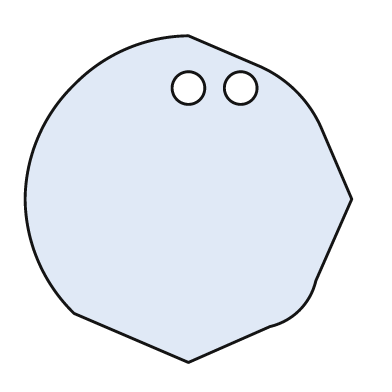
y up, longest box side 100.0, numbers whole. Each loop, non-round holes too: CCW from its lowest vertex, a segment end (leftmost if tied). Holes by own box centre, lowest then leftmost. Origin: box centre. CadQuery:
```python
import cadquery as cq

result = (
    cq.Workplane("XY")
    .moveTo(0.0, -50.0)
    .lineTo(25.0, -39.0)
    .threePointArc((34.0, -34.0), (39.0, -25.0))
    .lineTo(50.0, 0.0)
    .lineTo(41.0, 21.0)
    .threePointArc((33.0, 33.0), (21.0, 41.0))
    .lineTo(0.0, 50.0)
    .threePointArc((-19.0, 46.0), (-35.0, 35.0))
    .threePointArc((-46.0, 19.0), (-50.0, 0.0))
    .threePointArc((-46.0, -19.0), (-35.0, -35.0))
    .close()
    .moveTo(0.0, 34.0)
    .circle(5.0)
    .moveTo(16.0, 34.0)
    .circle(5.0)
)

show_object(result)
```